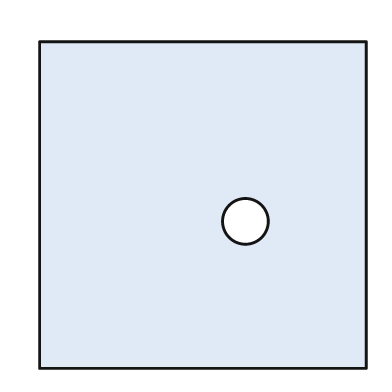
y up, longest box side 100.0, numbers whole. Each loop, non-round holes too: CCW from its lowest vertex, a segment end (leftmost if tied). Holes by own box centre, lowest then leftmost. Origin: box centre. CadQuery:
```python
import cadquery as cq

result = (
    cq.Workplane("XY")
    .moveTo(-50.0, -50.0)
    .lineTo(50.0, -50.0)
    .lineTo(50.0, 50.0)
    .lineTo(-50.0, 50.0)
    .close()
    .moveTo(13.0, -5.0)
    .circle(7.0)
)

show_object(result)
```